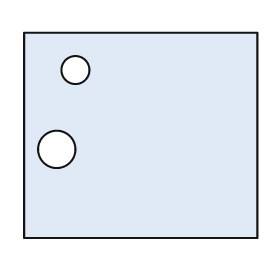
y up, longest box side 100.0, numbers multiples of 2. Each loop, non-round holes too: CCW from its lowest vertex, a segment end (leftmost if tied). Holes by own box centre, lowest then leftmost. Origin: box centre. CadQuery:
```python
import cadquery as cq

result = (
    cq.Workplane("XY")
    .moveTo(-50.0, -44.0)
    .lineTo(50.0, -44.0)
    .lineTo(50.0, 44.0)
    .lineTo(-50.0, 44.0)
    .close()
    .moveTo(-36.0, -6.0)
    .circle(8.0)
    .moveTo(-28.0, 28.0)
    .circle(6.0)
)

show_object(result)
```